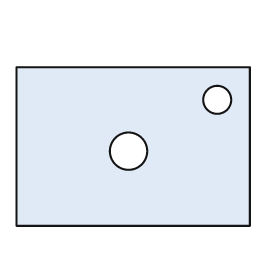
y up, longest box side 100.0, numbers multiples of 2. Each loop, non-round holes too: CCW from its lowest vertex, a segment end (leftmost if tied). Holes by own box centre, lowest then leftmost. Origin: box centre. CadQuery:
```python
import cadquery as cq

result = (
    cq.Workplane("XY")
    .moveTo(-50.0, -34.0)
    .lineTo(50.0, -34.0)
    .lineTo(50.0, 34.0)
    .lineTo(-50.0, 34.0)
    .close()
    .moveTo(-2.0, -2.0)
    .circle(8.0)
    .moveTo(36.0, 20.0)
    .circle(6.0)
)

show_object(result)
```